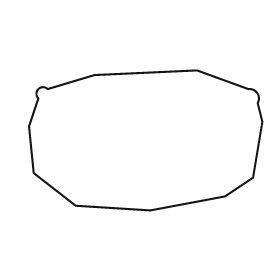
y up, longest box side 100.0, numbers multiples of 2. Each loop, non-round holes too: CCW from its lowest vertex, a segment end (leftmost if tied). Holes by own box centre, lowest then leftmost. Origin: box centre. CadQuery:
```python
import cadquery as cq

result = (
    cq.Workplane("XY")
    .moveTo(2.0, -30.0)
    .lineTo(34.0, -24.0)
    .lineTo(46.0, -16.0)
    .lineTo(50.0, 8.0)
    .lineTo(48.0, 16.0)
    .threePointArc((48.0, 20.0), (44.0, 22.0))
    .lineTo(22.0, 30.0)
    .lineTo(-22.0, 28.0)
    .lineTo(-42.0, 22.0)
    .threePointArc((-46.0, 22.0), (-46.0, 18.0))
    .lineTo(-50.0, 6.0)
    .lineTo(-48.0, -14.0)
    .lineTo(-30.0, -28.0)
    .close()
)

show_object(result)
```